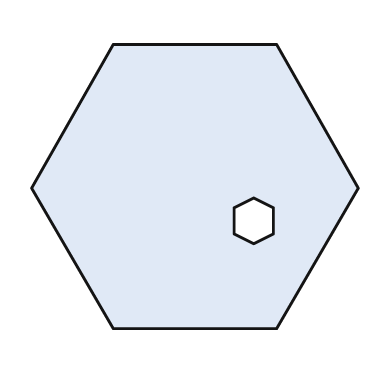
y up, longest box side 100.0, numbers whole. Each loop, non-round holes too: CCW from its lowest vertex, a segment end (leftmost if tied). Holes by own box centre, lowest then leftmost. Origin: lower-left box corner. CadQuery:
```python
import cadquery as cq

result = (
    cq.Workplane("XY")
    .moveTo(25.0, 0.0)
    .lineTo(75.0, 0.0)
    .lineTo(100.0, 43.0)
    .lineTo(75.0, 87.0)
    .lineTo(25.0, 87.0)
    .lineTo(0.0, 43.0)
    .close()
    .moveTo(68.0, 26.0)
    .lineTo(74.0, 29.0)
    .lineTo(74.0, 37.0)
    .lineTo(68.0, 40.0)
    .lineTo(62.0, 37.0)
    .lineTo(62.0, 29.0)
    .close()
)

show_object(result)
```